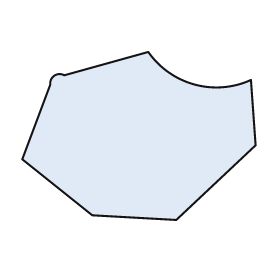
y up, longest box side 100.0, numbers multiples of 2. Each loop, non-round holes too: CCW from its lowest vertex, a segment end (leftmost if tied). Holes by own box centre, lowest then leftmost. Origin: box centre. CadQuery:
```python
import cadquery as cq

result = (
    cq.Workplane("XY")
    .moveTo(16.0, -36.0)
    .lineTo(50.0, -4.0)
    .lineTo(48.0, 24.0)
    .threePointArc((24.0, 22.0), (4.0, 36.0))
    .lineTo(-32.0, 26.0)
    .threePointArc((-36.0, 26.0), (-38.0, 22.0))
    .lineTo(-50.0, -10.0)
    .lineTo(-20.0, -34.0)
    .close()
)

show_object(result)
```